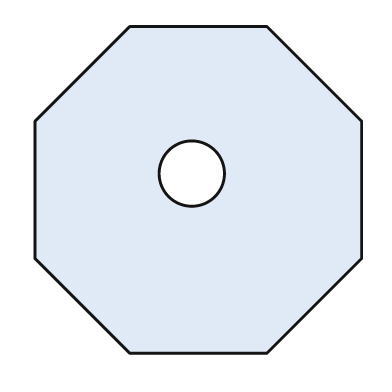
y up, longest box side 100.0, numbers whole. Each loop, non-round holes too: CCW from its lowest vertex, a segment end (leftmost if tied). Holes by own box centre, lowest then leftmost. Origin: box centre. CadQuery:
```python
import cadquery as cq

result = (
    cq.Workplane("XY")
    .moveTo(-21.0, -50.0)
    .lineTo(21.0, -50.0)
    .lineTo(50.0, -21.0)
    .lineTo(50.0, 21.0)
    .lineTo(21.0, 50.0)
    .lineTo(-21.0, 50.0)
    .lineTo(-50.0, 21.0)
    .lineTo(-50.0, -21.0)
    .close()
    .moveTo(-2.0, 5.0)
    .circle(10.0)
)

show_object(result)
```